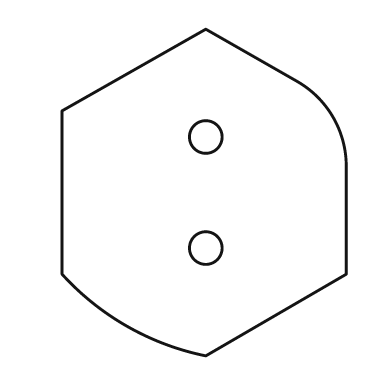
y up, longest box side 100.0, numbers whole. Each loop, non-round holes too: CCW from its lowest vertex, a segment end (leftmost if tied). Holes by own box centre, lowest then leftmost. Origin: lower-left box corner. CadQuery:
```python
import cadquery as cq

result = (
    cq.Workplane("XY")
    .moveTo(44.0, 0.0)
    .lineTo(87.0, 25.0)
    .lineTo(87.0, 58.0)
    .threePointArc((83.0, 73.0), (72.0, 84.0))
    .lineTo(44.0, 100.0)
    .lineTo(0.0, 75.0)
    .lineTo(0.0, 25.0)
    .threePointArc((20.0, 9.0), (44.0, 0.0))
    .close()
    .moveTo(44.0, 33.0)
    .circle(5.0)
    .moveTo(44.0, 67.0)
    .circle(5.0)
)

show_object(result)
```